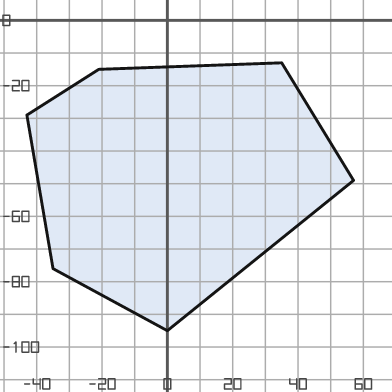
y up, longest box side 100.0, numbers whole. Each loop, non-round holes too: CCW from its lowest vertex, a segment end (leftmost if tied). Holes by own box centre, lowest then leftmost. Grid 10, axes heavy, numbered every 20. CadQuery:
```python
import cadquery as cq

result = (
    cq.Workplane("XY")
    .moveTo(0.0, -95.0)
    .lineTo(57.0, -49.0)
    .lineTo(35.0, -13.0)
    .lineTo(-21.0, -15.0)
    .lineTo(-43.0, -29.0)
    .lineTo(-35.0, -76.0)
    .close()
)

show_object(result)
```